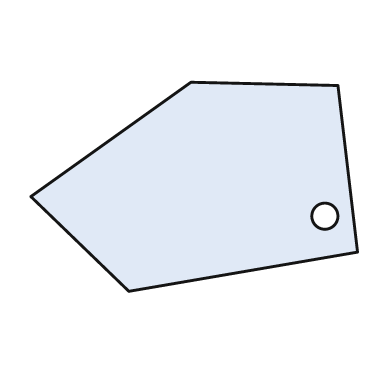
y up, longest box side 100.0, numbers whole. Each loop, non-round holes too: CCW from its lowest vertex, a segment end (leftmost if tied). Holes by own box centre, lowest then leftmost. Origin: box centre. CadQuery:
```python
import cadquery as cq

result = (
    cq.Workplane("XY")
    .moveTo(-20.0, -32.0)
    .lineTo(50.0, -20.0)
    .lineTo(44.0, 31.0)
    .lineTo(-1.0, 32.0)
    .lineTo(-50.0, -3.0)
    .close()
    .moveTo(40.0, -9.0)
    .circle(4.0)
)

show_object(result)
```